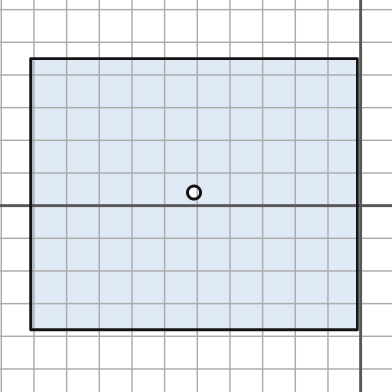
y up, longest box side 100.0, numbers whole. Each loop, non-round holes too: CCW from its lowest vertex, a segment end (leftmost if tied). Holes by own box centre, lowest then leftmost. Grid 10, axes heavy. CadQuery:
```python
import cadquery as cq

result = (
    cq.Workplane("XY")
    .moveTo(-101.0, -38.0)
    .lineTo(-1.0, -38.0)
    .lineTo(-1.0, 45.0)
    .lineTo(-101.0, 45.0)
    .close()
    .moveTo(-51.0, 4.0)
    .circle(2.0)
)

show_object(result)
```